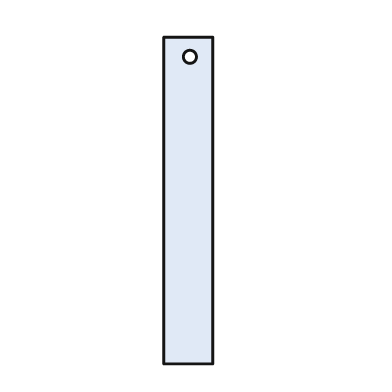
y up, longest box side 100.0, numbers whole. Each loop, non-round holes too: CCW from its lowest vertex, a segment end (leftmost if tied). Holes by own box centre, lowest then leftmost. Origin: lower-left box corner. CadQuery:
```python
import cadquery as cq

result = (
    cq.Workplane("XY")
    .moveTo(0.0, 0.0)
    .lineTo(15.0, 0.0)
    .lineTo(15.0, 100.0)
    .lineTo(0.0, 100.0)
    .close()
    .moveTo(8.0, 94.0)
    .circle(2.0)
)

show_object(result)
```